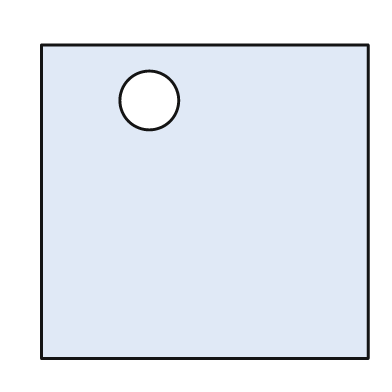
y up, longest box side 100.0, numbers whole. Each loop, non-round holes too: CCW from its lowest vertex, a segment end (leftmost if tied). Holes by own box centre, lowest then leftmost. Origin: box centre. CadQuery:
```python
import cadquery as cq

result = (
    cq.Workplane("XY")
    .moveTo(-50.0, -48.0)
    .lineTo(50.0, -48.0)
    .lineTo(50.0, 48.0)
    .lineTo(-50.0, 48.0)
    .close()
    .moveTo(-17.0, 31.0)
    .circle(9.0)
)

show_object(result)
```